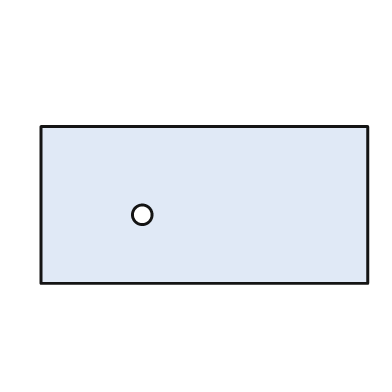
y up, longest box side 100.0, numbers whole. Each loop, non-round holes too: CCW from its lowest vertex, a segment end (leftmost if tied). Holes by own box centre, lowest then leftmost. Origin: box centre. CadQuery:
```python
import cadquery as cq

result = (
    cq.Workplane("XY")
    .moveTo(-50.0, -24.0)
    .lineTo(50.0, -24.0)
    .lineTo(50.0, 24.0)
    .lineTo(-50.0, 24.0)
    .close()
    .moveTo(-19.0, -3.0)
    .circle(3.0)
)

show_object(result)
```